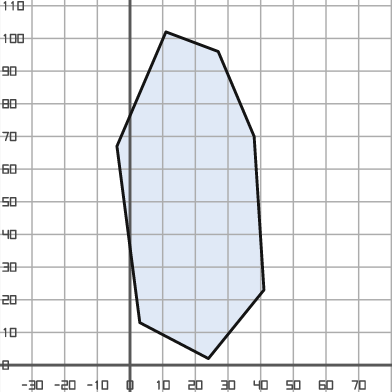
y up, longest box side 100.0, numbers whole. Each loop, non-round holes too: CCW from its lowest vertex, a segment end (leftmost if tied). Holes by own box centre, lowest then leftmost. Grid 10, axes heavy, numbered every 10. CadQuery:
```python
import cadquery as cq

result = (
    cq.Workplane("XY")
    .moveTo(24.0, 2.0)
    .lineTo(41.0, 23.0)
    .lineTo(38.0, 70.0)
    .lineTo(27.0, 96.0)
    .lineTo(11.0, 102.0)
    .lineTo(-4.0, 67.0)
    .lineTo(3.0, 13.0)
    .close()
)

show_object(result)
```